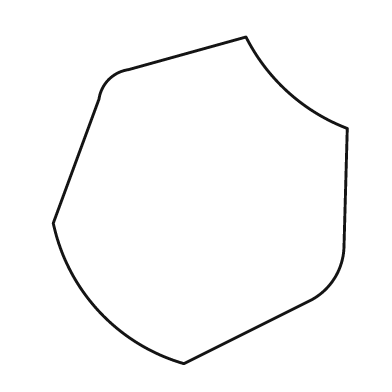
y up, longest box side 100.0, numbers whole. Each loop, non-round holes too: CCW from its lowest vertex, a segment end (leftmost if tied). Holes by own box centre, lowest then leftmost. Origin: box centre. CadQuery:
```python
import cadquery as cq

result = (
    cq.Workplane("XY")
    .moveTo(-5.0, -50.0)
    .lineTo(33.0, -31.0)
    .threePointArc((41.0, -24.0), (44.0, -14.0))
    .lineTo(45.0, 22.0)
    .threePointArc((27.0, 33.0), (14.0, 50.0))
    .lineTo(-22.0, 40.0)
    .threePointArc((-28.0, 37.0), (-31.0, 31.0))
    .lineTo(-45.0, -7.0)
    .threePointArc((-31.0, -34.0), (-5.0, -50.0))
    .close()
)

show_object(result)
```